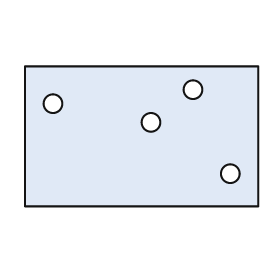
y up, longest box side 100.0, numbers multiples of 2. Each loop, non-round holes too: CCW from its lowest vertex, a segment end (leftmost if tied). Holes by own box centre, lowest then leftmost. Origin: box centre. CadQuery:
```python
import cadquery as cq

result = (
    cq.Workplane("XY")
    .moveTo(-50.0, -30.0)
    .lineTo(50.0, -30.0)
    .lineTo(50.0, 30.0)
    .lineTo(-50.0, 30.0)
    .close()
    .moveTo(38.0, -16.0)
    .circle(4.0)
    .moveTo(4.0, 6.0)
    .circle(4.0)
    .moveTo(-38.0, 14.0)
    .circle(4.0)
    .moveTo(22.0, 20.0)
    .circle(4.0)
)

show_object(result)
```